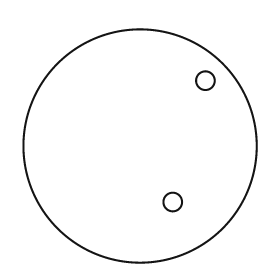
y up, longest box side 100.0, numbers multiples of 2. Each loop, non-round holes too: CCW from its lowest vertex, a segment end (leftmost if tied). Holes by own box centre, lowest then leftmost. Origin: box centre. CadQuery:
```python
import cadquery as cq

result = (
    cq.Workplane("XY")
    .moveTo(0.0, 0.0)
    .circle(50.0)
    .moveTo(14.0, -24.0)
    .circle(4.0)
    .moveTo(28.0, 28.0)
    .circle(4.0)
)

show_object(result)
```